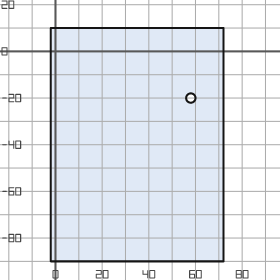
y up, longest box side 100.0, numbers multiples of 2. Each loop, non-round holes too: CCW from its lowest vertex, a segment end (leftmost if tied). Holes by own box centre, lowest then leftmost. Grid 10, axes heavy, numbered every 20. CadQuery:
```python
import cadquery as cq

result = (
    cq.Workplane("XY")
    .moveTo(-2.0, -90.0)
    .lineTo(72.0, -90.0)
    .lineTo(72.0, 10.0)
    .lineTo(-2.0, 10.0)
    .close()
    .moveTo(58.0, -20.0)
    .circle(2.0)
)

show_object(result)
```